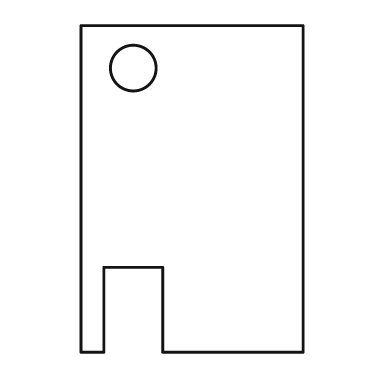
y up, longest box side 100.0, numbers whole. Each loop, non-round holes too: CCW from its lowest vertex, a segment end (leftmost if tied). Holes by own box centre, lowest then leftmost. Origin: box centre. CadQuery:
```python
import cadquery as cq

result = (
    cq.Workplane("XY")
    .moveTo(-34.0, -50.0)
    .lineTo(-27.0, -50.0)
    .lineTo(-27.0, -24.0)
    .lineTo(-9.0, -24.0)
    .lineTo(-9.0, -50.0)
    .lineTo(34.0, -50.0)
    .lineTo(34.0, 50.0)
    .lineTo(-34.0, 50.0)
    .close()
    .moveTo(-18.0, 37.0)
    .circle(7.0)
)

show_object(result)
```